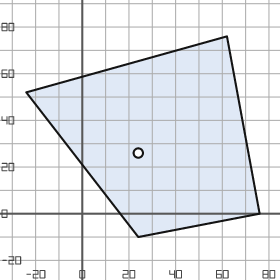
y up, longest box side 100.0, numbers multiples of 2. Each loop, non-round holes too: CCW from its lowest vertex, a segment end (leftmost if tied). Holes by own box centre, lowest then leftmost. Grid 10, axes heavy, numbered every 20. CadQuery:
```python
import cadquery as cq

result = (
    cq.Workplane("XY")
    .moveTo(24.0, -10.0)
    .lineTo(76.0, 0.0)
    .lineTo(62.0, 76.0)
    .lineTo(-24.0, 52.0)
    .close()
    .moveTo(24.0, 26.0)
    .circle(2.0)
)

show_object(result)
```